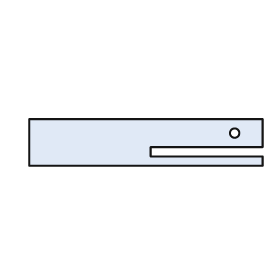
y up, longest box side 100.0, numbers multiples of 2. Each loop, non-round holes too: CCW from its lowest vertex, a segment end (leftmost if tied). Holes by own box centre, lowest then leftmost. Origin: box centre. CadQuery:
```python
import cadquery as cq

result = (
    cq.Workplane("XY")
    .moveTo(-50.0, -10.0)
    .lineTo(50.0, -10.0)
    .lineTo(50.0, -6.0)
    .lineTo(2.0, -6.0)
    .lineTo(2.0, -2.0)
    .lineTo(50.0, -2.0)
    .lineTo(50.0, 10.0)
    .lineTo(-50.0, 10.0)
    .close()
    .moveTo(38.0, 4.0)
    .circle(2.0)
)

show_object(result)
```